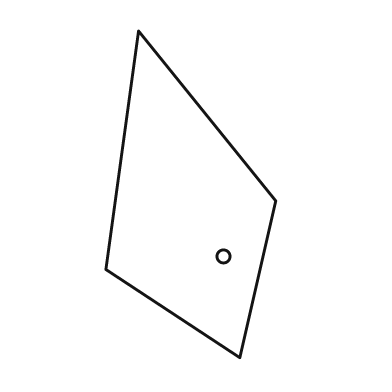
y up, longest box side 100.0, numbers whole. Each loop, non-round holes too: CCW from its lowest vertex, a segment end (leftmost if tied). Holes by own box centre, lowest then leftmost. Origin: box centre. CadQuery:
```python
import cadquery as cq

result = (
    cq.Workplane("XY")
    .moveTo(15.0, -50.0)
    .lineTo(26.0, -2.0)
    .lineTo(-16.0, 50.0)
    .lineTo(-26.0, -23.0)
    .close()
    .moveTo(10.0, -19.0)
    .circle(2.0)
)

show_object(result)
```